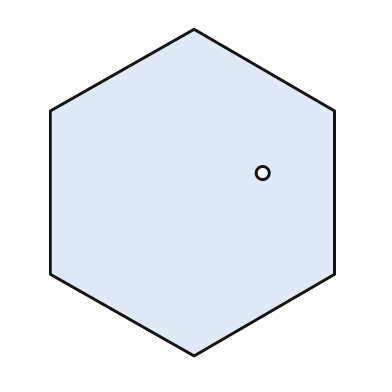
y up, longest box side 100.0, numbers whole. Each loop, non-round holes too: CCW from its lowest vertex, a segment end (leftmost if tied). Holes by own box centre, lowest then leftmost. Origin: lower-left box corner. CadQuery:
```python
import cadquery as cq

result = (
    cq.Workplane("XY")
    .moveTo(44.0, 0.0)
    .lineTo(87.0, 25.0)
    .lineTo(87.0, 75.0)
    .lineTo(44.0, 100.0)
    .lineTo(0.0, 75.0)
    .lineTo(0.0, 25.0)
    .close()
    .moveTo(65.0, 56.0)
    .circle(2.0)
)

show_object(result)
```